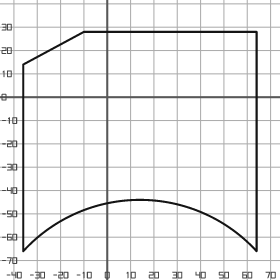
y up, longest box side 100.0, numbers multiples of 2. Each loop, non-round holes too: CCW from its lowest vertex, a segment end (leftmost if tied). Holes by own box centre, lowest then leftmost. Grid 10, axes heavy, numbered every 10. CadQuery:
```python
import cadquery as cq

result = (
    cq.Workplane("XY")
    .moveTo(-36.0, -66.0)
    .threePointArc((14.0, -44.0), (64.0, -66.0))
    .lineTo(64.0, 28.0)
    .lineTo(-10.0, 28.0)
    .lineTo(-36.0, 14.0)
    .close()
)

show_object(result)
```